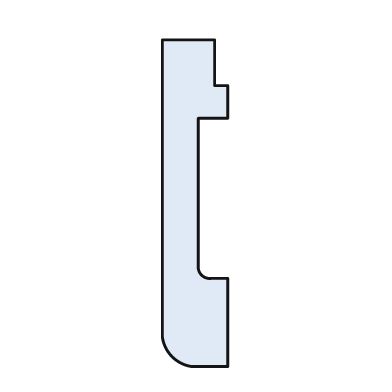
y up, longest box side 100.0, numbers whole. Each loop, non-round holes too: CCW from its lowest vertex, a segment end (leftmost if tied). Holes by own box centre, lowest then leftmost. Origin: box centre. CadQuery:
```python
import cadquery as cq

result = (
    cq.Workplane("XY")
    .moveTo(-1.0, -50.0)
    .lineTo(10.0, -50.0)
    .lineTo(10.0, -23.0)
    .lineTo(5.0, -23.0)
    .threePointArc((2.0, -22.0), (1.0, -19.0))
    .lineTo(1.0, 26.0)
    .lineTo(10.0, 26.0)
    .lineTo(10.0, 36.0)
    .lineTo(6.0, 36.0)
    .lineTo(6.0, 50.0)
    .lineTo(-10.0, 50.0)
    .lineTo(-10.0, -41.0)
    .threePointArc((-7.0, -47.0), (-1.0, -50.0))
    .close()
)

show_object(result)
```